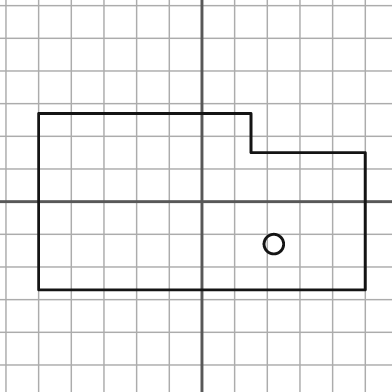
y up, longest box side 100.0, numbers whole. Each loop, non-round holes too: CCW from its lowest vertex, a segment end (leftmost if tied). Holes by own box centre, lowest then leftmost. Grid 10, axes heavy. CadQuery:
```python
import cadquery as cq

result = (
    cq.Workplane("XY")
    .moveTo(-50.0, -27.0)
    .lineTo(50.0, -27.0)
    .lineTo(50.0, 15.0)
    .lineTo(15.0, 15.0)
    .lineTo(15.0, 27.0)
    .lineTo(-50.0, 27.0)
    .close()
    .moveTo(22.0, -13.0)
    .circle(3.0)
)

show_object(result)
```